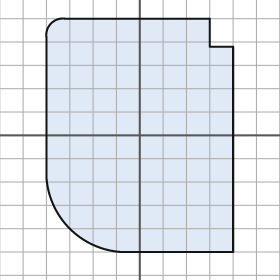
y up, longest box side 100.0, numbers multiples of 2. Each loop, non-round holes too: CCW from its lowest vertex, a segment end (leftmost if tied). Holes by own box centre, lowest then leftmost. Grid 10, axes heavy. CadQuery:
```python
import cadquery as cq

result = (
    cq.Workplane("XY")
    .moveTo(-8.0, -50.0)
    .lineTo(40.0, -50.0)
    .lineTo(40.0, 38.0)
    .lineTo(30.0, 38.0)
    .lineTo(30.0, 50.0)
    .lineTo(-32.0, 50.0)
    .threePointArc((-38.0, 48.0), (-40.0, 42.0))
    .lineTo(-40.0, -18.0)
    .threePointArc((-30.0, -40.0), (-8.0, -50.0))
    .close()
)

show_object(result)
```